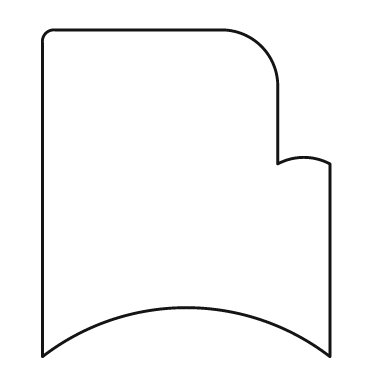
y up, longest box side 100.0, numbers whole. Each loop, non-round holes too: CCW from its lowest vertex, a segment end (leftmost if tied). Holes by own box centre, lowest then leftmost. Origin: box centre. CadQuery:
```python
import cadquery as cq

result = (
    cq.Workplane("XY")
    .moveTo(-44.0, -50.0)
    .threePointArc((0.0, -35.0), (44.0, -50.0))
    .lineTo(44.0, 9.0)
    .threePointArc((36.0, 11.0), (28.0, 9.0))
    .lineTo(28.0, 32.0)
    .threePointArc((23.0, 45.0), (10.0, 50.0))
    .lineTo(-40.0, 50.0)
    .threePointArc((-43.0, 49.0), (-44.0, 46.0))
    .close()
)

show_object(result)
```